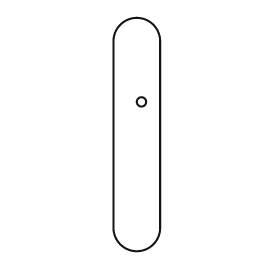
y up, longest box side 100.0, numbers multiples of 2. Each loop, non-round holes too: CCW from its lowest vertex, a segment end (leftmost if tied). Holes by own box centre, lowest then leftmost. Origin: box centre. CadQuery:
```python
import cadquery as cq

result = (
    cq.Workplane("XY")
    .moveTo(-10.0, -40.0)
    .threePointArc((0.0, -50.0), (10.0, -40.0))
    .lineTo(10.0, 40.0)
    .threePointArc((0.0, 50.0), (-10.0, 40.0))
    .close()
    .moveTo(2.0, 14.0)
    .circle(2.0)
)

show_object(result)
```